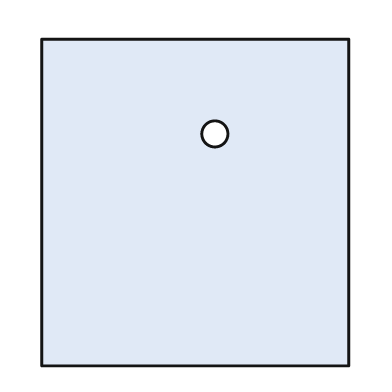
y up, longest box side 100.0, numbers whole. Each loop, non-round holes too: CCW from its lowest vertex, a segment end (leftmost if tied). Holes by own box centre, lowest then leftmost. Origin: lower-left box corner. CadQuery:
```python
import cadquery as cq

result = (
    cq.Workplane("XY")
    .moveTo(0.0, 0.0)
    .lineTo(94.0, 0.0)
    .lineTo(94.0, 100.0)
    .lineTo(0.0, 100.0)
    .close()
    .moveTo(53.0, 71.0)
    .circle(4.0)
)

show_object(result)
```